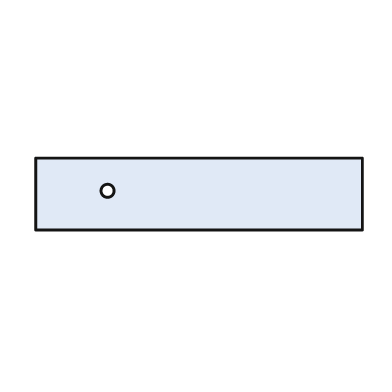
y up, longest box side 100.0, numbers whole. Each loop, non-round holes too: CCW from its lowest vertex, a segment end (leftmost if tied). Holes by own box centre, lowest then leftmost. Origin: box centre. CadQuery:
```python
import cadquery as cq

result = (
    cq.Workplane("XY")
    .moveTo(-50.0, -11.0)
    .lineTo(50.0, -11.0)
    .lineTo(50.0, 11.0)
    .lineTo(-50.0, 11.0)
    .close()
    .moveTo(-28.0, 1.0)
    .circle(2.0)
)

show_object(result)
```